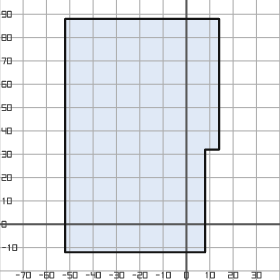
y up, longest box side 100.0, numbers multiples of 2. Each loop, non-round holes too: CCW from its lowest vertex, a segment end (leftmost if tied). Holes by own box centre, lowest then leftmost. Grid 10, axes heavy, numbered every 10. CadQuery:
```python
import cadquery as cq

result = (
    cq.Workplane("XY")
    .moveTo(-52.0, -12.0)
    .lineTo(8.0, -12.0)
    .lineTo(8.0, 32.0)
    .lineTo(14.0, 32.0)
    .lineTo(14.0, 88.0)
    .lineTo(-52.0, 88.0)
    .close()
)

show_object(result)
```